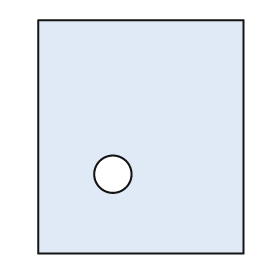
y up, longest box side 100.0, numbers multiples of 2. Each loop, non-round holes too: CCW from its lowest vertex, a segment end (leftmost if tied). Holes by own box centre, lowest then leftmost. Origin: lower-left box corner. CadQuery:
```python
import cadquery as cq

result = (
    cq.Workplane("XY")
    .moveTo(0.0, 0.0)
    .lineTo(88.0, 0.0)
    .lineTo(88.0, 100.0)
    .lineTo(0.0, 100.0)
    .close()
    .moveTo(32.0, 34.0)
    .circle(8.0)
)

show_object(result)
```